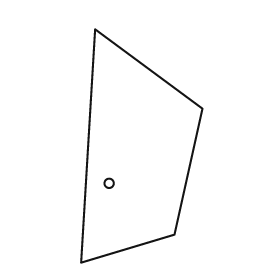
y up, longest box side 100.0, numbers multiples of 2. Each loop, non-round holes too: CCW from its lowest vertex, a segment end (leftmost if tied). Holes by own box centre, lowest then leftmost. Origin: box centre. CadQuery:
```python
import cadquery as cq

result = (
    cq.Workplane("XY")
    .moveTo(-26.0, -50.0)
    .lineTo(14.0, -38.0)
    .lineTo(26.0, 16.0)
    .lineTo(-20.0, 50.0)
    .close()
    .moveTo(-14.0, -16.0)
    .circle(2.0)
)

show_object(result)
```